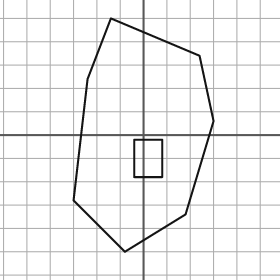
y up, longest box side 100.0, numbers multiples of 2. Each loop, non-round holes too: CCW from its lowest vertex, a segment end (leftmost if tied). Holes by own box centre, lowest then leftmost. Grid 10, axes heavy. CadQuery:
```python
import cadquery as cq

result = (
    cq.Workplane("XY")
    .moveTo(-8.0, -50.0)
    .lineTo(18.0, -34.0)
    .lineTo(30.0, 6.0)
    .lineTo(24.0, 34.0)
    .lineTo(-14.0, 50.0)
    .lineTo(-24.0, 24.0)
    .lineTo(-30.0, -28.0)
    .close()
    .moveTo(-4.0, -18.0)
    .lineTo(8.0, -18.0)
    .lineTo(8.0, -2.0)
    .lineTo(-4.0, -2.0)
    .close()
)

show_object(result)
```